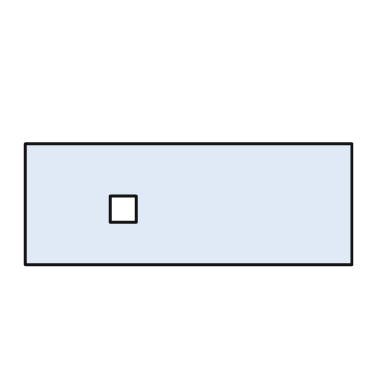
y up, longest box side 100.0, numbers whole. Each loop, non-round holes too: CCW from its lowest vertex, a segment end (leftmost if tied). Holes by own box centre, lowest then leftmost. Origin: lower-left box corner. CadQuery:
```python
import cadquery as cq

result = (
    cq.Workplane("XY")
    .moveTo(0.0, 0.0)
    .lineTo(100.0, 0.0)
    .lineTo(100.0, 37.0)
    .lineTo(0.0, 37.0)
    .close()
    .moveTo(26.0, 13.0)
    .lineTo(34.0, 13.0)
    .lineTo(34.0, 21.0)
    .lineTo(26.0, 21.0)
    .close()
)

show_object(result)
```